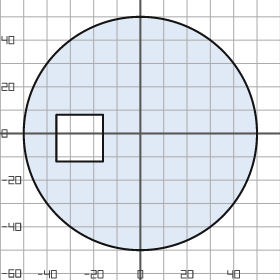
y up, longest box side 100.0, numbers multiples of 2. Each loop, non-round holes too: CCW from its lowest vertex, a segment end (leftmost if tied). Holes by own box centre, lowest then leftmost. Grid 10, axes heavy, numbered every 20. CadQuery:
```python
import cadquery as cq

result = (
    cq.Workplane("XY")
    .moveTo(0.0, 0.0)
    .circle(50.0)
    .moveTo(-36.0, -12.0)
    .lineTo(-16.0, -12.0)
    .lineTo(-16.0, 8.0)
    .lineTo(-36.0, 8.0)
    .close()
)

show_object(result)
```